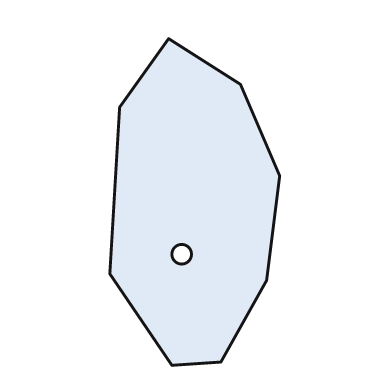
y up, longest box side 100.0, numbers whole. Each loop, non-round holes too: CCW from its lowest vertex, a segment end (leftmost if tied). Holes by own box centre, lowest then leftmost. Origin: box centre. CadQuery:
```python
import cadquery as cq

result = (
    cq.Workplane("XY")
    .moveTo(-7.0, -50.0)
    .lineTo(8.0, -49.0)
    .lineTo(22.0, -24.0)
    .lineTo(26.0, 8.0)
    .lineTo(14.0, 36.0)
    .lineTo(-8.0, 50.0)
    .lineTo(-23.0, 29.0)
    .lineTo(-26.0, -22.0)
    .close()
    .moveTo(-4.0, -16.0)
    .circle(3.0)
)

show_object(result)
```